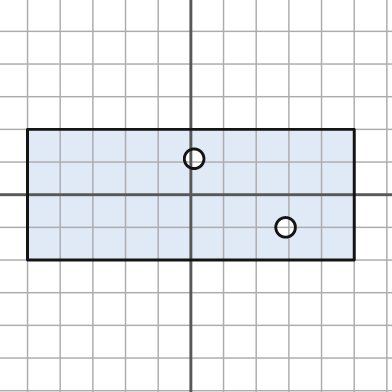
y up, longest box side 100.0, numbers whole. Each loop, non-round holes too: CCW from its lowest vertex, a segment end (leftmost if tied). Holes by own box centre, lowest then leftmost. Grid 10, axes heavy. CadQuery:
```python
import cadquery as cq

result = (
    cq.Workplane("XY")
    .moveTo(-50.0, -20.0)
    .lineTo(50.0, -20.0)
    .lineTo(50.0, 20.0)
    .lineTo(-50.0, 20.0)
    .close()
    .moveTo(29.0, -10.0)
    .circle(3.0)
    .moveTo(1.0, 11.0)
    .circle(3.0)
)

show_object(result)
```